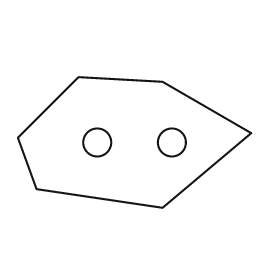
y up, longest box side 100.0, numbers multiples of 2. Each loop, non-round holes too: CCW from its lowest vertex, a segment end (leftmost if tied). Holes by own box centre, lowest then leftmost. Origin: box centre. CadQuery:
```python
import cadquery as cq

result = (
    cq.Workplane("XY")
    .moveTo(12.0, -28.0)
    .lineTo(50.0, 4.0)
    .lineTo(12.0, 26.0)
    .lineTo(-24.0, 28.0)
    .lineTo(-50.0, 2.0)
    .lineTo(-42.0, -20.0)
    .close()
    .moveTo(-16.0, 0.0)
    .circle(6.0)
    .moveTo(16.0, 0.0)
    .circle(6.0)
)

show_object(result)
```